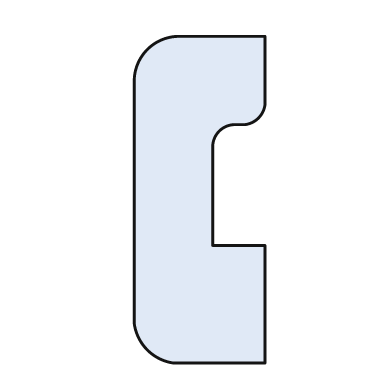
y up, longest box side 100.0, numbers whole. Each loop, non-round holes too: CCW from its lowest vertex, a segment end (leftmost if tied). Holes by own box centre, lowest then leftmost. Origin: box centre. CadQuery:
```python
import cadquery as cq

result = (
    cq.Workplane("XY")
    .moveTo(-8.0, -50.0)
    .lineTo(20.0, -50.0)
    .lineTo(20.0, -14.0)
    .lineTo(4.0, -14.0)
    .lineTo(4.0, 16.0)
    .threePointArc((6.0, 21.0), (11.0, 23.0))
    .lineTo(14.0, 23.0)
    .threePointArc((18.0, 25.0), (20.0, 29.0))
    .lineTo(20.0, 50.0)
    .lineTo(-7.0, 50.0)
    .threePointArc((-16.0, 46.0), (-20.0, 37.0))
    .lineTo(-20.0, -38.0)
    .threePointArc((-16.0, -46.0), (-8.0, -50.0))
    .close()
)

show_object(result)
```